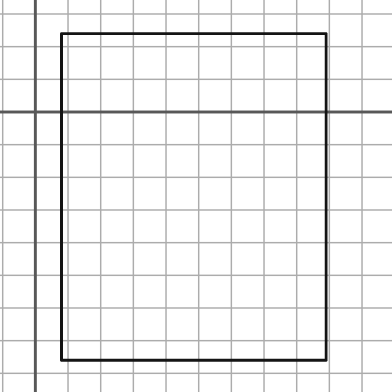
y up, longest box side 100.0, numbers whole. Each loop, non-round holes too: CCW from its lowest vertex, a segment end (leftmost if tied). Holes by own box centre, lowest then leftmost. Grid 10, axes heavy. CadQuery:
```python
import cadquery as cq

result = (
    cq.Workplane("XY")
    .moveTo(8.0, -76.0)
    .lineTo(89.0, -76.0)
    .lineTo(89.0, 24.0)
    .lineTo(8.0, 24.0)
    .close()
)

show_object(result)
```